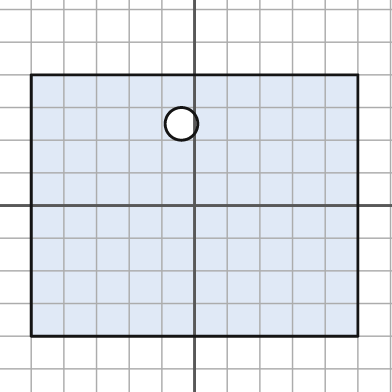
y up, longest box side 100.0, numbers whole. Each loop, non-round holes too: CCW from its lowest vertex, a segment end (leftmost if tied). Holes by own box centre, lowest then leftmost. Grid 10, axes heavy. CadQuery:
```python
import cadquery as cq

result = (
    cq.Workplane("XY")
    .moveTo(-50.0, -40.0)
    .lineTo(50.0, -40.0)
    .lineTo(50.0, 40.0)
    .lineTo(-50.0, 40.0)
    .close()
    .moveTo(-4.0, 25.0)
    .circle(5.0)
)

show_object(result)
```